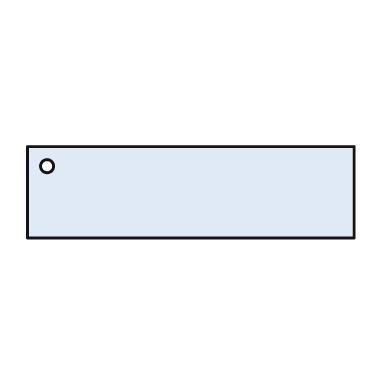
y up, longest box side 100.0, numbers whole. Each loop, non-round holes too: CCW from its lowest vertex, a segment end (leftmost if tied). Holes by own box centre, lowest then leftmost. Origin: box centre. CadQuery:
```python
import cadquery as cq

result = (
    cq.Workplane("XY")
    .moveTo(-50.0, -14.0)
    .lineTo(50.0, -14.0)
    .lineTo(50.0, 14.0)
    .lineTo(-50.0, 14.0)
    .close()
    .moveTo(-44.0, 8.0)
    .circle(2.0)
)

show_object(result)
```